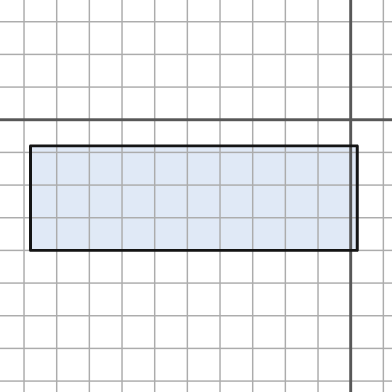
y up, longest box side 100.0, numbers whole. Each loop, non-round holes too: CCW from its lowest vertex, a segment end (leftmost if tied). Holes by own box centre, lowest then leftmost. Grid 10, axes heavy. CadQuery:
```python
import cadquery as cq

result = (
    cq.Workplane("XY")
    .moveTo(-98.0, -40.0)
    .lineTo(2.0, -40.0)
    .lineTo(2.0, -8.0)
    .lineTo(-98.0, -8.0)
    .close()
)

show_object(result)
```